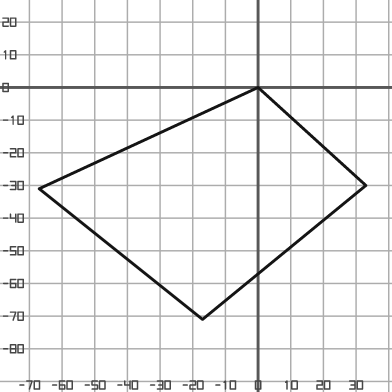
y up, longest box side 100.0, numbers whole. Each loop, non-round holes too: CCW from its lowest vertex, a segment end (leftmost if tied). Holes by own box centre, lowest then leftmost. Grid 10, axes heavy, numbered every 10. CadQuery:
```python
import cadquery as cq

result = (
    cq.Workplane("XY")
    .moveTo(-17.0, -71.0)
    .lineTo(33.0, -30.0)
    .lineTo(0.0, 0.0)
    .lineTo(-67.0, -31.0)
    .close()
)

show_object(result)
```